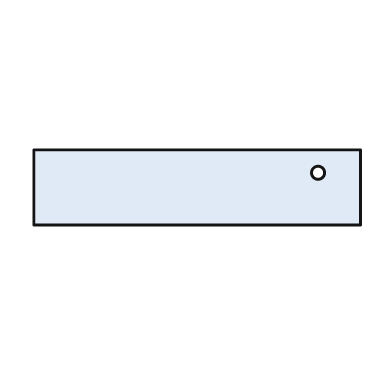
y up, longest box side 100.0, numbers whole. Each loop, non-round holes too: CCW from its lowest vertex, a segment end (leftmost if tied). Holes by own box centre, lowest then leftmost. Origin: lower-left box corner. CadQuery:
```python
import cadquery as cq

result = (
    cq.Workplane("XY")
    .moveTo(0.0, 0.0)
    .lineTo(100.0, 0.0)
    .lineTo(100.0, 23.0)
    .lineTo(0.0, 23.0)
    .close()
    .moveTo(87.0, 16.0)
    .circle(2.0)
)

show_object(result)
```